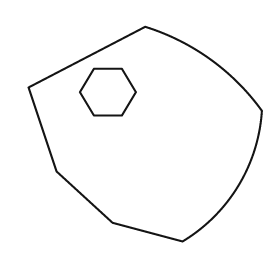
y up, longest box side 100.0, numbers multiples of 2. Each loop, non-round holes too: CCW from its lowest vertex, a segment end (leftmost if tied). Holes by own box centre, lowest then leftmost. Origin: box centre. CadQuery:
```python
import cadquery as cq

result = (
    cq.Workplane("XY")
    .moveTo(16.0, -46.0)
    .threePointArc((40.0, -22.0), (50.0, 10.0))
    .threePointArc((28.0, 32.0), (0.0, 46.0))
    .lineTo(-50.0, 20.0)
    .lineTo(-38.0, -16.0)
    .lineTo(-14.0, -38.0)
    .close()
    .moveTo(-22.0, 8.0)
    .lineTo(-10.0, 8.0)
    .lineTo(-4.0, 18.0)
    .lineTo(-10.0, 28.0)
    .lineTo(-22.0, 28.0)
    .lineTo(-28.0, 18.0)
    .close()
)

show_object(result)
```